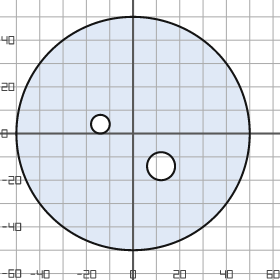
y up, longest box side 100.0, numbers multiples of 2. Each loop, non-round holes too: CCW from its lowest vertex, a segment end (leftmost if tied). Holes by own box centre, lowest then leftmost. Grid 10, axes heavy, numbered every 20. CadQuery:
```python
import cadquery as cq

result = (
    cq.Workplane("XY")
    .moveTo(0.0, 0.0)
    .circle(50.0)
    .moveTo(12.0, -14.0)
    .circle(6.0)
    .moveTo(-14.0, 4.0)
    .circle(4.0)
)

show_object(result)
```